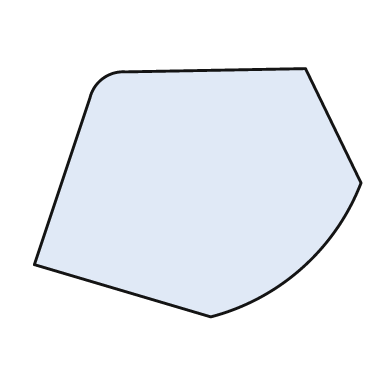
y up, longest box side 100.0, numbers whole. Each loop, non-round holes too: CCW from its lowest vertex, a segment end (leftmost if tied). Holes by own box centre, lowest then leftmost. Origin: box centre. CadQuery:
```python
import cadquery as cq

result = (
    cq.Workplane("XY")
    .moveTo(4.0, -38.0)
    .threePointArc((32.0, -23.0), (50.0, 3.0))
    .lineTo(33.0, 38.0)
    .lineTo(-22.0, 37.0)
    .threePointArc((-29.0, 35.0), (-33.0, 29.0))
    .lineTo(-50.0, -22.0)
    .close()
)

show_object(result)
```